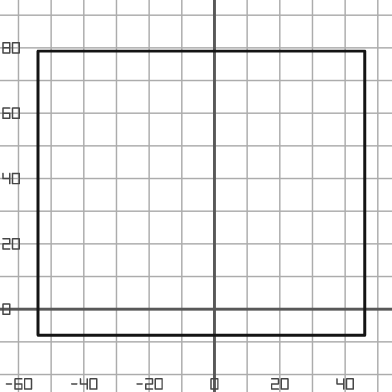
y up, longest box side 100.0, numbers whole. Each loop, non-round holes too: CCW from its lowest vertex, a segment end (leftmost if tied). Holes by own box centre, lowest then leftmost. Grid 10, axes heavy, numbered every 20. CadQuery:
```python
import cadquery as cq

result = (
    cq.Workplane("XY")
    .moveTo(-54.0, -8.0)
    .lineTo(46.0, -8.0)
    .lineTo(46.0, 79.0)
    .lineTo(-54.0, 79.0)
    .close()
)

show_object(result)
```